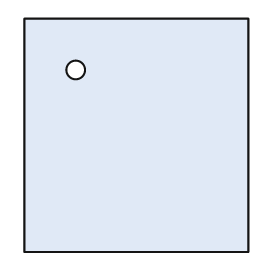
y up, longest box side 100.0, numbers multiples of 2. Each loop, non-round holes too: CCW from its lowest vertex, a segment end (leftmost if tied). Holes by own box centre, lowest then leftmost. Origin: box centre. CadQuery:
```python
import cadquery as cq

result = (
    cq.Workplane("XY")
    .moveTo(-48.0, -50.0)
    .lineTo(48.0, -50.0)
    .lineTo(48.0, 50.0)
    .lineTo(-48.0, 50.0)
    .close()
    .moveTo(-26.0, 28.0)
    .circle(4.0)
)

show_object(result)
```